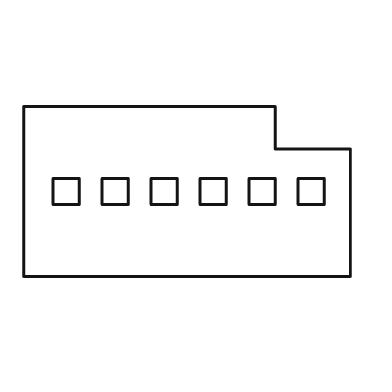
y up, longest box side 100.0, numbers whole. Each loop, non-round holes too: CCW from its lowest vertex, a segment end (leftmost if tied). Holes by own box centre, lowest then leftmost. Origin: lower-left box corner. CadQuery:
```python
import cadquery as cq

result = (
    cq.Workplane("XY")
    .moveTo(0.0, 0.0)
    .lineTo(100.0, 0.0)
    .lineTo(100.0, 39.0)
    .lineTo(77.0, 39.0)
    .lineTo(77.0, 52.0)
    .lineTo(0.0, 52.0)
    .close()
    .moveTo(9.0, 22.0)
    .lineTo(17.0, 22.0)
    .lineTo(17.0, 30.0)
    .lineTo(9.0, 30.0)
    .close()
    .moveTo(24.0, 22.0)
    .lineTo(32.0, 22.0)
    .lineTo(32.0, 30.0)
    .lineTo(24.0, 30.0)
    .close()
    .moveTo(39.0, 22.0)
    .lineTo(47.0, 22.0)
    .lineTo(47.0, 30.0)
    .lineTo(39.0, 30.0)
    .close()
    .moveTo(54.0, 22.0)
    .lineTo(62.0, 22.0)
    .lineTo(62.0, 30.0)
    .lineTo(54.0, 30.0)
    .close()
    .moveTo(69.0, 22.0)
    .lineTo(77.0, 22.0)
    .lineTo(77.0, 30.0)
    .lineTo(69.0, 30.0)
    .close()
    .moveTo(84.0, 22.0)
    .lineTo(92.0, 22.0)
    .lineTo(92.0, 30.0)
    .lineTo(84.0, 30.0)
    .close()
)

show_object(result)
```